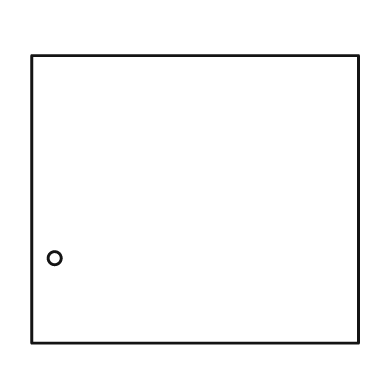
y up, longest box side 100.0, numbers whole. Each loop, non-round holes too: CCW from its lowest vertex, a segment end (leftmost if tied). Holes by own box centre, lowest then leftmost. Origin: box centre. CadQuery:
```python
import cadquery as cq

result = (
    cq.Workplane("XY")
    .moveTo(-50.0, -44.0)
    .lineTo(50.0, -44.0)
    .lineTo(50.0, 44.0)
    .lineTo(-50.0, 44.0)
    .close()
    .moveTo(-43.0, -18.0)
    .circle(2.0)
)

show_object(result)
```